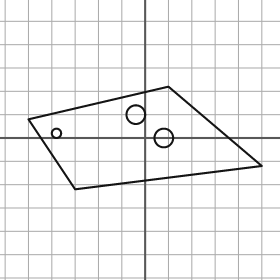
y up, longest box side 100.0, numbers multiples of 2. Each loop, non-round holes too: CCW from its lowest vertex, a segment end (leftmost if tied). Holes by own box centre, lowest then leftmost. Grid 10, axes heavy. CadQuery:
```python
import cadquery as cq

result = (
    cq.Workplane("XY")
    .moveTo(-30.0, -22.0)
    .lineTo(50.0, -12.0)
    .lineTo(10.0, 22.0)
    .lineTo(-50.0, 8.0)
    .close()
    .moveTo(8.0, 0.0)
    .circle(4.0)
    .moveTo(-38.0, 2.0)
    .circle(2.0)
    .moveTo(-4.0, 10.0)
    .circle(4.0)
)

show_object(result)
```